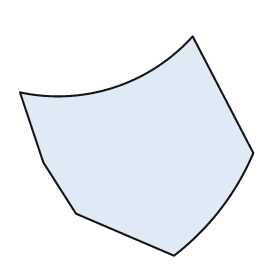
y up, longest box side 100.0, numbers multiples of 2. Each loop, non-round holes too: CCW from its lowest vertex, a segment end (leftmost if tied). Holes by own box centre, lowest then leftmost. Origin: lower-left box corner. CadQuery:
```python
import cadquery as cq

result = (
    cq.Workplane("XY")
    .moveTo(66.0, 0.0)
    .threePointArc((86.0, 20.0), (100.0, 44.0))
    .lineTo(74.0, 94.0)
    .threePointArc((40.0, 72.0), (0.0, 70.0))
    .lineTo(10.0, 40.0)
    .lineTo(24.0, 18.0)
    .close()
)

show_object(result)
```